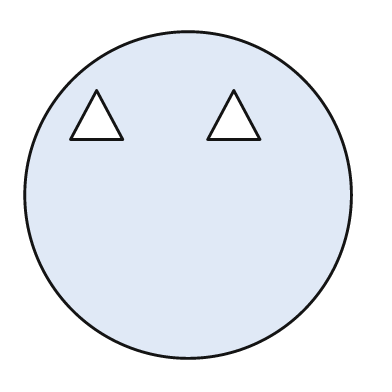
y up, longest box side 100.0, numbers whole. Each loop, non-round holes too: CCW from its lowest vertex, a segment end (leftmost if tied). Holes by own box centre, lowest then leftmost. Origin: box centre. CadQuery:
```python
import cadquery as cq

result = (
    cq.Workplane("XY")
    .moveTo(0.0, 0.0)
    .circle(50.0)
    .moveTo(-36.0, 17.0)
    .lineTo(-20.0, 17.0)
    .lineTo(-28.0, 32.0)
    .close()
    .moveTo(6.0, 17.0)
    .lineTo(22.0, 17.0)
    .lineTo(14.0, 32.0)
    .close()
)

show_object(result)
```